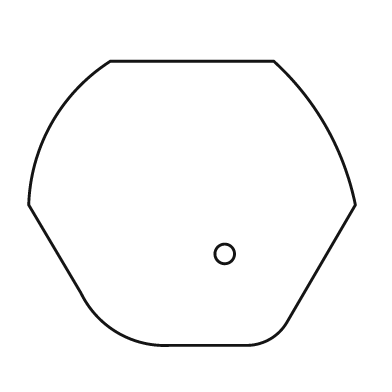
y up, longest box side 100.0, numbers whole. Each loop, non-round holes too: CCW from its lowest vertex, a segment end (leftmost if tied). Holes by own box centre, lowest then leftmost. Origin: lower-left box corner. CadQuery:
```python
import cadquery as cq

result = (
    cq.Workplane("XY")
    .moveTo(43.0, 0.0)
    .lineTo(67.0, 0.0)
    .threePointArc((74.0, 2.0), (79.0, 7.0))
    .lineTo(100.0, 43.0)
    .threePointArc((91.0, 67.0), (75.0, 87.0))
    .lineTo(25.0, 87.0)
    .threePointArc((7.0, 68.0), (0.0, 43.0))
    .lineTo(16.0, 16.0)
    .threePointArc((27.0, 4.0), (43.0, 0.0))
    .close()
    .moveTo(60.0, 28.0)
    .circle(3.0)
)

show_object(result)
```